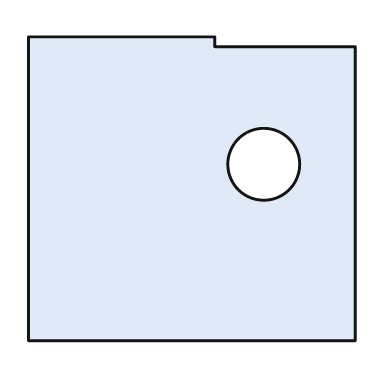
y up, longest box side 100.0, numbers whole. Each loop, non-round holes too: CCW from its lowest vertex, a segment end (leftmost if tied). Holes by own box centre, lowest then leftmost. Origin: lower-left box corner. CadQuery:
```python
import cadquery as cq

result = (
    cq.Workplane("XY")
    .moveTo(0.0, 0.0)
    .lineTo(100.0, 0.0)
    .lineTo(100.0, 90.0)
    .lineTo(57.0, 90.0)
    .lineTo(57.0, 93.0)
    .lineTo(0.0, 93.0)
    .close()
    .moveTo(72.0, 54.0)
    .circle(11.0)
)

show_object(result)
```